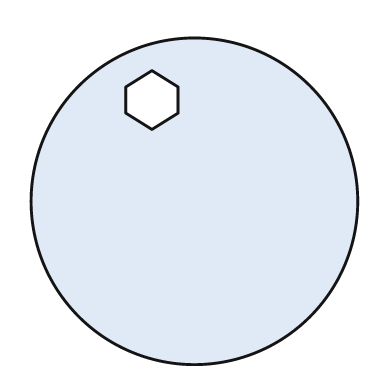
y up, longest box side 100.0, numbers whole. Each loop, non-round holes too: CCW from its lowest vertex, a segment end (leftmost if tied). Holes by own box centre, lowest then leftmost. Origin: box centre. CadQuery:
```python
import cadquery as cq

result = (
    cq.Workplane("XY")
    .moveTo(0.0, 0.0)
    .circle(50.0)
    .moveTo(-13.0, 22.0)
    .lineTo(-5.0, 27.0)
    .lineTo(-5.0, 35.0)
    .lineTo(-13.0, 40.0)
    .lineTo(-21.0, 35.0)
    .lineTo(-21.0, 27.0)
    .close()
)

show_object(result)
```